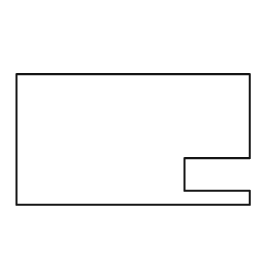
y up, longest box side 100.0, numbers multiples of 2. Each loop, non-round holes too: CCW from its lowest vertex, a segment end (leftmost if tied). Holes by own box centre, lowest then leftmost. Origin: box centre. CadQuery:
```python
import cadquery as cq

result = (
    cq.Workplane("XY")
    .moveTo(-50.0, -28.0)
    .lineTo(50.0, -28.0)
    .lineTo(50.0, -22.0)
    .lineTo(22.0, -22.0)
    .lineTo(22.0, -8.0)
    .lineTo(50.0, -8.0)
    .lineTo(50.0, 28.0)
    .lineTo(-50.0, 28.0)
    .close()
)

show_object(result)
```